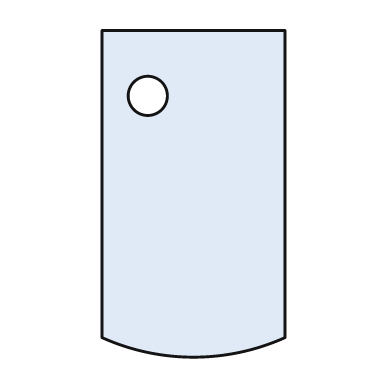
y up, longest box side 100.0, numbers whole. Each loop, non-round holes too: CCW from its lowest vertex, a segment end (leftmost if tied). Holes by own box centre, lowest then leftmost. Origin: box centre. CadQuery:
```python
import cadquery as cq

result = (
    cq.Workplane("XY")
    .moveTo(-28.0, -44.0)
    .threePointArc((0.0, -50.0), (28.0, -44.0))
    .lineTo(28.0, 50.0)
    .lineTo(-28.0, 50.0)
    .close()
    .moveTo(-14.0, 30.0)
    .circle(6.0)
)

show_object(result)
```